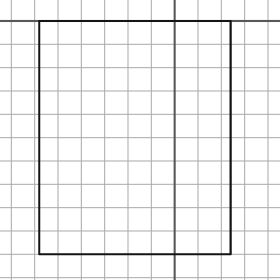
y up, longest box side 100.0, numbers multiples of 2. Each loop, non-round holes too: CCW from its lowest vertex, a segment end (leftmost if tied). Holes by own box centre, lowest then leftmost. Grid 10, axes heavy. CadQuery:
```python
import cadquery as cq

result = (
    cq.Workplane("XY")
    .moveTo(-58.0, -100.0)
    .lineTo(24.0, -100.0)
    .lineTo(24.0, 0.0)
    .lineTo(-58.0, 0.0)
    .close()
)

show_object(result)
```